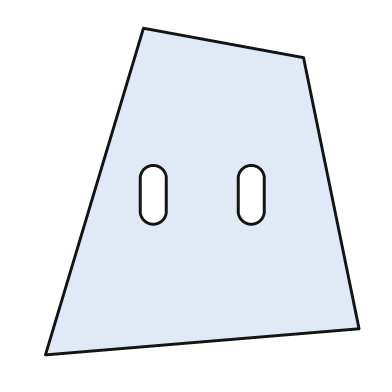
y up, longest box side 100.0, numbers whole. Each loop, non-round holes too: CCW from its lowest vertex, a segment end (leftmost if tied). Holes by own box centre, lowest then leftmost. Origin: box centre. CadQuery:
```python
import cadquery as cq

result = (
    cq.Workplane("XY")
    .moveTo(-48.0, -50.0)
    .lineTo(48.0, -42.0)
    .lineTo(31.0, 41.0)
    .lineTo(-18.0, 50.0)
    .close()
    .moveTo(-19.0, -6.0)
    .threePointArc((-15.0, -10.0), (-11.0, -6.0))
    .lineTo(-11.0, 4.0)
    .threePointArc((-15.0, 8.0), (-19.0, 4.0))
    .close()
    .moveTo(11.0, -6.0)
    .threePointArc((15.0, -10.0), (19.0, -6.0))
    .lineTo(19.0, 4.0)
    .threePointArc((15.0, 8.0), (11.0, 4.0))
    .close()
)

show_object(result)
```